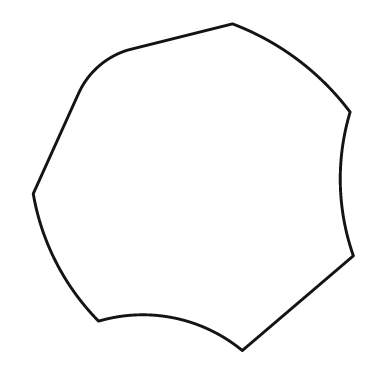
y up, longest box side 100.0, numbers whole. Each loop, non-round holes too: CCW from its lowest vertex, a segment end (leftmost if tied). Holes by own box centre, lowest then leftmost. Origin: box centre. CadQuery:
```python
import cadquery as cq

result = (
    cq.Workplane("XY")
    .moveTo(15.0, -50.0)
    .lineTo(49.0, -21.0)
    .threePointArc((45.0, 1.0), (48.0, 23.0))
    .threePointArc((32.0, 39.0), (12.0, 50.0))
    .lineTo(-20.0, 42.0)
    .threePointArc((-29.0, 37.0), (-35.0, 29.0))
    .lineTo(-49.0, -2.0)
    .threePointArc((-42.0, -23.0), (-29.0, -41.0))
    .threePointArc((-6.0, -40.0), (15.0, -50.0))
    .close()
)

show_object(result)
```